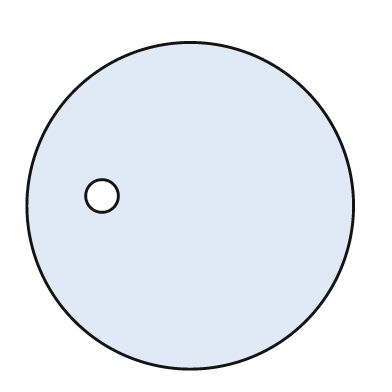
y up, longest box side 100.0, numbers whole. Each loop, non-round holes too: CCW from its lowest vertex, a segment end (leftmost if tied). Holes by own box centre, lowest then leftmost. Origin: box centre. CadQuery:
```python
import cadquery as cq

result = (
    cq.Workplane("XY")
    .moveTo(0.0, 0.0)
    .circle(50.0)
    .moveTo(-27.0, 3.0)
    .circle(5.0)
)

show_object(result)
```